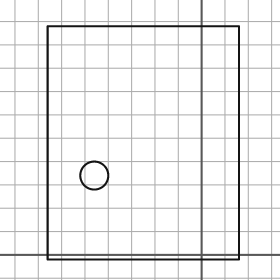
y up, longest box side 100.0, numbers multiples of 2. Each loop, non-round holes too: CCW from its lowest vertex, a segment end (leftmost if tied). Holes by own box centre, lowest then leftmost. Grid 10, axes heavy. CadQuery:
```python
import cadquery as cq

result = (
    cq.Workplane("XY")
    .moveTo(-66.0, -2.0)
    .lineTo(16.0, -2.0)
    .lineTo(16.0, 98.0)
    .lineTo(-66.0, 98.0)
    .close()
    .moveTo(-46.0, 34.0)
    .circle(6.0)
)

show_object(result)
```